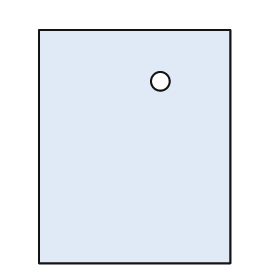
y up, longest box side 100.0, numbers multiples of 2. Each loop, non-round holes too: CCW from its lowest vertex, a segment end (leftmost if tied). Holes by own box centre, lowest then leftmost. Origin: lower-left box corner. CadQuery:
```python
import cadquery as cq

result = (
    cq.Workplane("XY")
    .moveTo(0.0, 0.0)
    .lineTo(82.0, 0.0)
    .lineTo(82.0, 100.0)
    .lineTo(0.0, 100.0)
    .close()
    .moveTo(52.0, 78.0)
    .circle(4.0)
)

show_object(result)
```